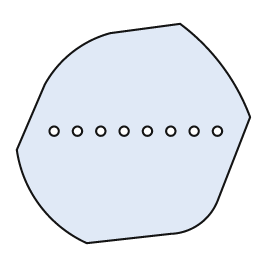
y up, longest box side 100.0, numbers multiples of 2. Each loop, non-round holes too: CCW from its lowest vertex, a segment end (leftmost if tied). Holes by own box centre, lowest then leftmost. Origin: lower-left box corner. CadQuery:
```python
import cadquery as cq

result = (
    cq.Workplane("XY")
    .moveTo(30.0, 0.0)
    .lineTo(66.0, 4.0)
    .threePointArc((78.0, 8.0), (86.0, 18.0))
    .lineTo(100.0, 54.0)
    .threePointArc((88.0, 76.0), (70.0, 94.0))
    .lineTo(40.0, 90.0)
    .threePointArc((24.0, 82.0), (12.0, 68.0))
    .lineTo(0.0, 40.0)
    .threePointArc((10.0, 16.0), (30.0, 0.0))
    .close()
    .moveTo(16.0, 48.0)
    .circle(2.0)
    .moveTo(26.0, 48.0)
    .circle(2.0)
    .moveTo(36.0, 48.0)
    .circle(2.0)
    .moveTo(46.0, 48.0)
    .circle(2.0)
    .moveTo(56.0, 48.0)
    .circle(2.0)
    .moveTo(66.0, 48.0)
    .circle(2.0)
    .moveTo(76.0, 48.0)
    .circle(2.0)
    .moveTo(86.0, 48.0)
    .circle(2.0)
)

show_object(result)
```